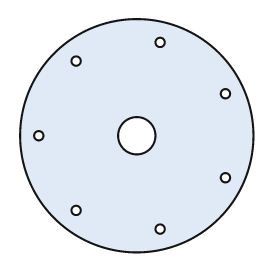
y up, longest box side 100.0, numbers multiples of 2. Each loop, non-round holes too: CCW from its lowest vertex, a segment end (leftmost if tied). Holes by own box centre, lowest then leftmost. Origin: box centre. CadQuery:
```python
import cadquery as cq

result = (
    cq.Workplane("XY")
    .moveTo(0.0, 0.0)
    .circle(50.0)
    .moveTo(10.0, -40.0)
    .circle(2.0)
    .moveTo(-26.0, -32.0)
    .circle(2.0)
    .moveTo(38.0, -18.0)
    .circle(2.0)
    .moveTo(-42.0, 0.0)
    .circle(2.0)
    .moveTo(0.0, 0.0)
    .circle(8.0)
    .moveTo(38.0, 18.0)
    .circle(2.0)
    .moveTo(-26.0, 32.0)
    .circle(2.0)
    .moveTo(10.0, 40.0)
    .circle(2.0)
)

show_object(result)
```